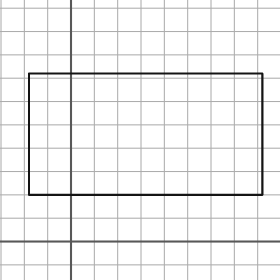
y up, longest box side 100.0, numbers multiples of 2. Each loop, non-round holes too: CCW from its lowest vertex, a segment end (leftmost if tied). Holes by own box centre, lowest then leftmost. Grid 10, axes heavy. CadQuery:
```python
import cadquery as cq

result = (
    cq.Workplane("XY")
    .moveTo(-18.0, 20.0)
    .lineTo(82.0, 20.0)
    .lineTo(82.0, 72.0)
    .lineTo(-18.0, 72.0)
    .close()
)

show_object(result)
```